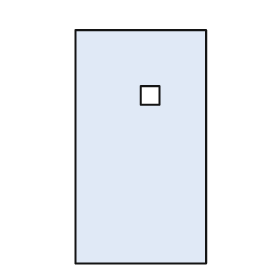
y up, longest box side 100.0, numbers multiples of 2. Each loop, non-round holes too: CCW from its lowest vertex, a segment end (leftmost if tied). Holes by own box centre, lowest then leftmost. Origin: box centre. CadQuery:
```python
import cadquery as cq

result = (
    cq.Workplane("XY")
    .moveTo(-28.0, -50.0)
    .lineTo(28.0, -50.0)
    .lineTo(28.0, 50.0)
    .lineTo(-28.0, 50.0)
    .close()
    .moveTo(0.0, 18.0)
    .lineTo(8.0, 18.0)
    .lineTo(8.0, 26.0)
    .lineTo(0.0, 26.0)
    .close()
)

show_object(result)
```